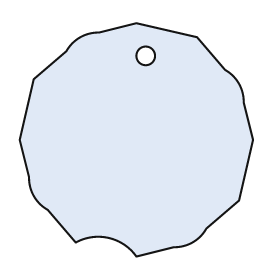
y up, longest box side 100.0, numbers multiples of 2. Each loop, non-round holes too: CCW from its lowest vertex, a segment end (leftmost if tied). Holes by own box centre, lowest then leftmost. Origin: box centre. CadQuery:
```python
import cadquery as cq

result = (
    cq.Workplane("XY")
    .moveTo(0.0, -50.0)
    .lineTo(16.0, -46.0)
    .threePointArc((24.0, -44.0), (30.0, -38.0))
    .lineTo(44.0, -26.0)
    .lineTo(50.0, 0.0)
    .lineTo(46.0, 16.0)
    .threePointArc((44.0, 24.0), (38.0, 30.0))
    .lineTo(26.0, 44.0)
    .lineTo(0.0, 50.0)
    .lineTo(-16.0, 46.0)
    .threePointArc((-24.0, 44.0), (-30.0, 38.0))
    .lineTo(-44.0, 26.0)
    .lineTo(-50.0, 0.0)
    .lineTo(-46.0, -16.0)
    .threePointArc((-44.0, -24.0), (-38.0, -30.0))
    .lineTo(-26.0, -44.0)
    .threePointArc((-12.0, -42.0), (0.0, -50.0))
    .close()
    .moveTo(4.0, 36.0)
    .circle(4.0)
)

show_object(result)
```